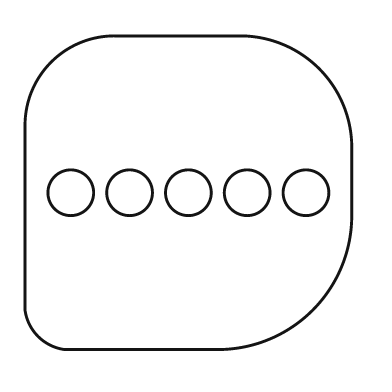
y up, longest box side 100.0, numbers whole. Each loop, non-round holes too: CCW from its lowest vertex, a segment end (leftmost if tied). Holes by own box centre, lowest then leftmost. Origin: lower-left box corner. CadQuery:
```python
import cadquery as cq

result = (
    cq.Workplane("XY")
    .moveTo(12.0, 0.0)
    .lineTo(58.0, 0.0)
    .threePointArc((88.0, 12.0), (100.0, 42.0))
    .lineTo(100.0, 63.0)
    .threePointArc((90.0, 86.0), (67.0, 96.0))
    .lineTo(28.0, 96.0)
    .threePointArc((8.0, 88.0), (0.0, 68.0))
    .lineTo(0.0, 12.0)
    .threePointArc((4.0, 4.0), (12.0, 0.0))
    .close()
    .moveTo(14.0, 48.0)
    .circle(7.0)
    .moveTo(32.0, 48.0)
    .circle(7.0)
    .moveTo(50.0, 48.0)
    .circle(7.0)
    .moveTo(68.0, 48.0)
    .circle(7.0)
    .moveTo(86.0, 48.0)
    .circle(7.0)
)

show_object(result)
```